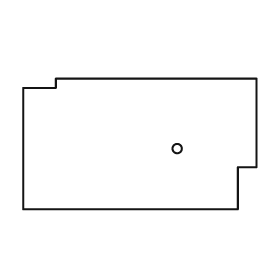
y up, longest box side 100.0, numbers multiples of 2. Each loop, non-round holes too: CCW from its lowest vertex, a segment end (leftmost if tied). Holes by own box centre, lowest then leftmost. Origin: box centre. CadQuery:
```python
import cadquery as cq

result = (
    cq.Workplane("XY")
    .moveTo(-50.0, -28.0)
    .lineTo(42.0, -28.0)
    .lineTo(42.0, -10.0)
    .lineTo(50.0, -10.0)
    .lineTo(50.0, 28.0)
    .lineTo(-36.0, 28.0)
    .lineTo(-36.0, 24.0)
    .lineTo(-50.0, 24.0)
    .close()
    .moveTo(16.0, -2.0)
    .circle(2.0)
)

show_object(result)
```